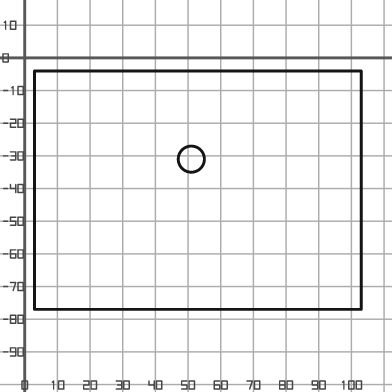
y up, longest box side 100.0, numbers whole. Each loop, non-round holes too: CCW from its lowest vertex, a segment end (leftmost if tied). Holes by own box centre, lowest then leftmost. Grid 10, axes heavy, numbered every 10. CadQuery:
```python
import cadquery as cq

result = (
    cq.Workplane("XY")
    .moveTo(3.0, -77.0)
    .lineTo(103.0, -77.0)
    .lineTo(103.0, -4.0)
    .lineTo(3.0, -4.0)
    .close()
    .moveTo(51.0, -31.0)
    .circle(4.0)
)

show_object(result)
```